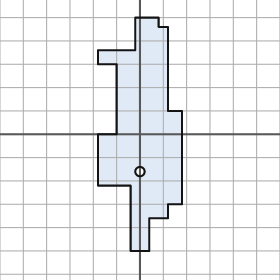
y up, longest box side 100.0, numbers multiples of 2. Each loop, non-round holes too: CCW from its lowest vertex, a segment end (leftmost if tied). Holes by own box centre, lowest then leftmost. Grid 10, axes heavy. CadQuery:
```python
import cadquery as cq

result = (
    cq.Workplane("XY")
    .moveTo(-4.0, -50.0)
    .lineTo(4.0, -50.0)
    .lineTo(4.0, -36.0)
    .lineTo(12.0, -36.0)
    .lineTo(12.0, -30.0)
    .lineTo(18.0, -30.0)
    .lineTo(18.0, 10.0)
    .lineTo(12.0, 10.0)
    .lineTo(12.0, 46.0)
    .lineTo(8.0, 46.0)
    .lineTo(8.0, 50.0)
    .lineTo(-2.0, 50.0)
    .lineTo(-2.0, 36.0)
    .lineTo(-18.0, 36.0)
    .lineTo(-18.0, 30.0)
    .lineTo(-10.0, 30.0)
    .lineTo(-10.0, 0.0)
    .lineTo(-18.0, 0.0)
    .lineTo(-18.0, -22.0)
    .lineTo(-4.0, -22.0)
    .close()
    .moveTo(0.0, -16.0)
    .circle(2.0)
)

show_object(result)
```